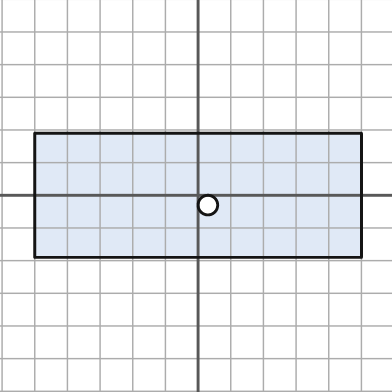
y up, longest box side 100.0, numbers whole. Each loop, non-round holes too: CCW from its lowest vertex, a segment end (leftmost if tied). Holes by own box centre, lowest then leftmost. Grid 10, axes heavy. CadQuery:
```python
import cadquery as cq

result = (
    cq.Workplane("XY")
    .moveTo(-50.0, -19.0)
    .lineTo(50.0, -19.0)
    .lineTo(50.0, 19.0)
    .lineTo(-50.0, 19.0)
    .close()
    .moveTo(3.0, -3.0)
    .circle(3.0)
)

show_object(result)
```